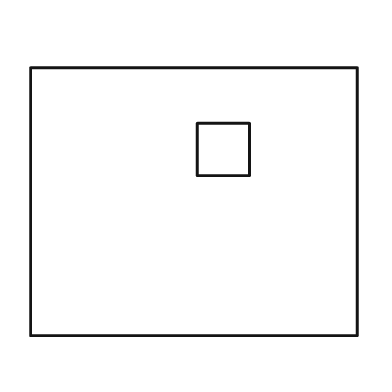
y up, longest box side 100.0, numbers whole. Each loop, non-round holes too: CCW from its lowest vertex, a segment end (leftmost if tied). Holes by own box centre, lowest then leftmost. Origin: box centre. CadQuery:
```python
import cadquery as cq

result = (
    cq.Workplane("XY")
    .moveTo(-50.0, -41.0)
    .lineTo(50.0, -41.0)
    .lineTo(50.0, 41.0)
    .lineTo(-50.0, 41.0)
    .close()
    .moveTo(1.0, 8.0)
    .lineTo(17.0, 8.0)
    .lineTo(17.0, 24.0)
    .lineTo(1.0, 24.0)
    .close()
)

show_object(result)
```